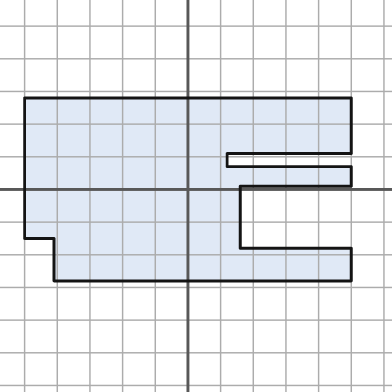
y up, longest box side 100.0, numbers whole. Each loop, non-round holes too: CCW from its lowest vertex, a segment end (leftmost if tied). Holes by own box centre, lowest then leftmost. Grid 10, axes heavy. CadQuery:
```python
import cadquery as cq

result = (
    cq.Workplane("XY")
    .moveTo(-41.0, -28.0)
    .lineTo(50.0, -28.0)
    .lineTo(50.0, -18.0)
    .lineTo(16.0, -18.0)
    .lineTo(16.0, 1.0)
    .lineTo(50.0, 1.0)
    .lineTo(50.0, 7.0)
    .lineTo(12.0, 7.0)
    .lineTo(12.0, 11.0)
    .lineTo(50.0, 11.0)
    .lineTo(50.0, 28.0)
    .lineTo(-50.0, 28.0)
    .lineTo(-50.0, -15.0)
    .lineTo(-41.0, -15.0)
    .close()
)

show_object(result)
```